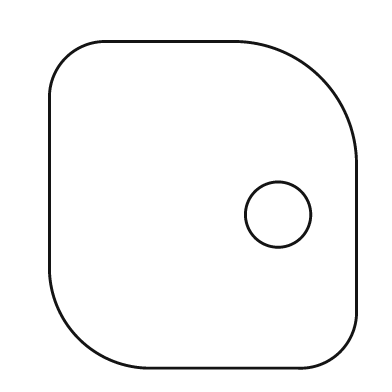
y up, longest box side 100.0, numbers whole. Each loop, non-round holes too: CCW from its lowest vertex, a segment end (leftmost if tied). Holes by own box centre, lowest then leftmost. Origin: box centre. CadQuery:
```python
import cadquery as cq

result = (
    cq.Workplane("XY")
    .moveTo(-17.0, -50.0)
    .lineTo(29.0, -50.0)
    .threePointArc((42.0, -45.0), (47.0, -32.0))
    .lineTo(47.0, 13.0)
    .threePointArc((36.0, 39.0), (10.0, 50.0))
    .lineTo(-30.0, 50.0)
    .threePointArc((-42.0, 45.0), (-47.0, 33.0))
    .lineTo(-47.0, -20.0)
    .threePointArc((-38.0, -41.0), (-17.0, -50.0))
    .close()
    .moveTo(23.0, -3.0)
    .circle(10.0)
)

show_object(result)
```